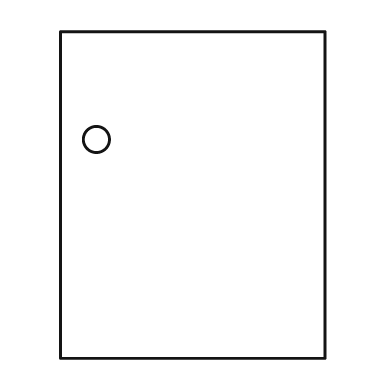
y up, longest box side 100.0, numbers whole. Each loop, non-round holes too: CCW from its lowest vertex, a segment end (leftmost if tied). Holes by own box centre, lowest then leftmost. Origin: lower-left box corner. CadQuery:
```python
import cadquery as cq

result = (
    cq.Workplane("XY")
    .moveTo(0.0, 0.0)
    .lineTo(81.0, 0.0)
    .lineTo(81.0, 100.0)
    .lineTo(0.0, 100.0)
    .close()
    .moveTo(11.0, 67.0)
    .circle(4.0)
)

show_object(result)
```